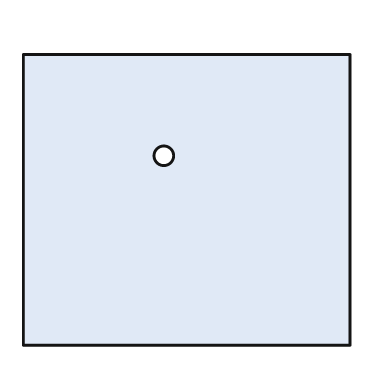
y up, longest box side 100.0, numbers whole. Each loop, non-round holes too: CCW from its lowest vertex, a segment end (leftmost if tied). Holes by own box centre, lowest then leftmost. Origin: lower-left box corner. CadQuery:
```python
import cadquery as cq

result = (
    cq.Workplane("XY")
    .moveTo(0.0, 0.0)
    .lineTo(100.0, 0.0)
    .lineTo(100.0, 89.0)
    .lineTo(0.0, 89.0)
    .close()
    .moveTo(43.0, 58.0)
    .circle(3.0)
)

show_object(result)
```